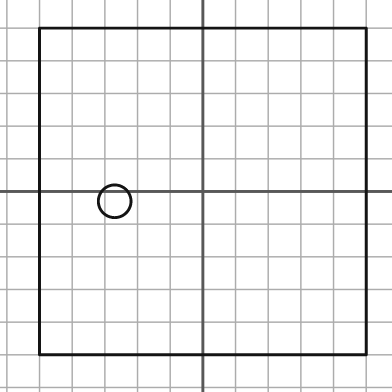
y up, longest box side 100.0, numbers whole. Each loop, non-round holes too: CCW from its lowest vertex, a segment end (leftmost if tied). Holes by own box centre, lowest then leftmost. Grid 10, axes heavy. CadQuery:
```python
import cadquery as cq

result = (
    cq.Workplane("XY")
    .moveTo(-50.0, -50.0)
    .lineTo(50.0, -50.0)
    .lineTo(50.0, 50.0)
    .lineTo(-50.0, 50.0)
    .close()
    .moveTo(-27.0, -3.0)
    .circle(5.0)
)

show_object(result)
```